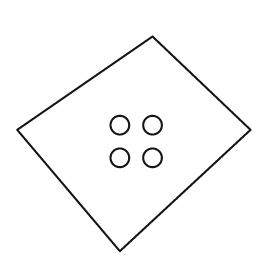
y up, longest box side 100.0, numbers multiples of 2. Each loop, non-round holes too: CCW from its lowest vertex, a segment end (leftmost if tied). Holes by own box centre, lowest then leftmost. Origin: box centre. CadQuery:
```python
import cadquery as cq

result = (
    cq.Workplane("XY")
    .moveTo(-6.0, -46.0)
    .lineTo(50.0, 6.0)
    .lineTo(8.0, 46.0)
    .lineTo(-50.0, 6.0)
    .close()
    .moveTo(-6.0, -6.0)
    .circle(4.0)
    .moveTo(8.0, -6.0)
    .circle(4.0)
    .moveTo(-6.0, 8.0)
    .circle(4.0)
    .moveTo(8.0, 8.0)
    .circle(4.0)
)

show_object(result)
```